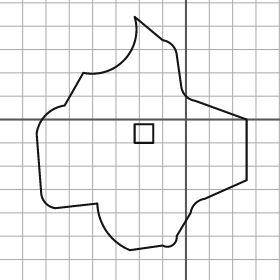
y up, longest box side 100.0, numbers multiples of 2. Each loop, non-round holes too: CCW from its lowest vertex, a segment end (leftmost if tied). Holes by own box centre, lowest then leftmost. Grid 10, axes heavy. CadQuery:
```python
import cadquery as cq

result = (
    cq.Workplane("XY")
    .moveTo(-24.0, -56.0)
    .lineTo(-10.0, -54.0)
    .threePointArc((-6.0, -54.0), (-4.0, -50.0))
    .lineTo(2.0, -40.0)
    .threePointArc((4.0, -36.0), (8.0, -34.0))
    .lineTo(26.0, -26.0)
    .lineTo(26.0, 0.0)
    .lineTo(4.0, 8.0)
    .threePointArc((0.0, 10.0), (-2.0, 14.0))
    .lineTo(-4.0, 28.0)
    .threePointArc((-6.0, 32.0), (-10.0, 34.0))
    .lineTo(-22.0, 44.0)
    .threePointArc((-26.0, 26.0), (-44.0, 20.0))
    .lineTo(-52.0, 6.0)
    .threePointArc((-60.0, 2.0), (-64.0, -6.0))
    .lineTo(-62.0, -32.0)
    .threePointArc((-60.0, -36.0), (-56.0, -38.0))
    .lineTo(-38.0, -36.0)
    .threePointArc((-34.0, -48.0), (-24.0, -56.0))
    .close()
    .moveTo(-22.0, -10.0)
    .lineTo(-14.0, -10.0)
    .lineTo(-14.0, -2.0)
    .lineTo(-22.0, -2.0)
    .close()
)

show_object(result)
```